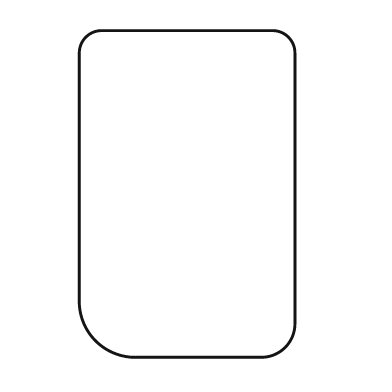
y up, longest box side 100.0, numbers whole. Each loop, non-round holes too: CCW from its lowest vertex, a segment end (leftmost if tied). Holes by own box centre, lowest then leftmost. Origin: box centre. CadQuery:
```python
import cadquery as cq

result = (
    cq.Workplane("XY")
    .moveTo(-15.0, -50.0)
    .lineTo(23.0, -50.0)
    .threePointArc((30.0, -47.0), (33.0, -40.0))
    .lineTo(33.0, 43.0)
    .threePointArc((31.0, 48.0), (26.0, 50.0))
    .lineTo(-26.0, 50.0)
    .threePointArc((-31.0, 48.0), (-33.0, 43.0))
    .lineTo(-33.0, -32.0)
    .threePointArc((-28.0, -45.0), (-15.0, -50.0))
    .close()
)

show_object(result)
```